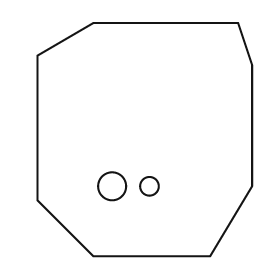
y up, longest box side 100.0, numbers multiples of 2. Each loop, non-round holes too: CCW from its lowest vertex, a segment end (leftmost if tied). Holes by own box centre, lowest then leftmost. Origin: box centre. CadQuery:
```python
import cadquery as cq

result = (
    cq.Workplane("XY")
    .moveTo(-22.0, -50.0)
    .lineTo(28.0, -50.0)
    .lineTo(46.0, -20.0)
    .lineTo(46.0, 32.0)
    .lineTo(40.0, 50.0)
    .lineTo(-22.0, 50.0)
    .lineTo(-46.0, 36.0)
    .lineTo(-46.0, -26.0)
    .close()
    .moveTo(-14.0, -20.0)
    .circle(6.0)
    .moveTo(2.0, -20.0)
    .circle(4.0)
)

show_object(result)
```